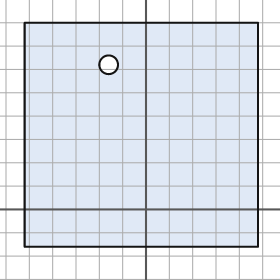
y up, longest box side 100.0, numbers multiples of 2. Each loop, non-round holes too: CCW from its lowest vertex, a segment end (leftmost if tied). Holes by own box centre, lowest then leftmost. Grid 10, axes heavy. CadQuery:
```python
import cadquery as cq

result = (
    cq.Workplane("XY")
    .moveTo(-52.0, -16.0)
    .lineTo(48.0, -16.0)
    .lineTo(48.0, 80.0)
    .lineTo(-52.0, 80.0)
    .close()
    .moveTo(-16.0, 62.0)
    .circle(4.0)
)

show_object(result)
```